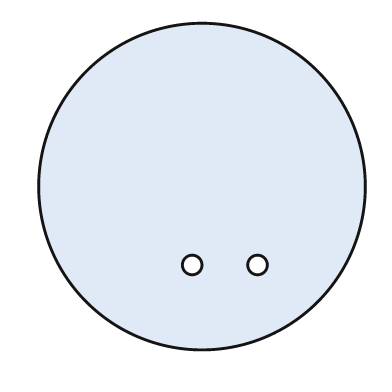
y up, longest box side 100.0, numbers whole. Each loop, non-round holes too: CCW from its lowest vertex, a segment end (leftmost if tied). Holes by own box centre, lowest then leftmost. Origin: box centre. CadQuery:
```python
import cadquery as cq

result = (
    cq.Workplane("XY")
    .moveTo(0.0, 0.0)
    .circle(50.0)
    .moveTo(-3.0, -24.0)
    .circle(3.0)
    .moveTo(17.0, -24.0)
    .circle(3.0)
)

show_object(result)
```